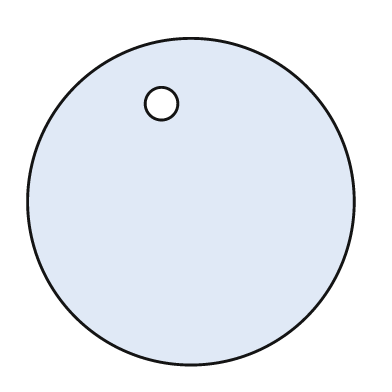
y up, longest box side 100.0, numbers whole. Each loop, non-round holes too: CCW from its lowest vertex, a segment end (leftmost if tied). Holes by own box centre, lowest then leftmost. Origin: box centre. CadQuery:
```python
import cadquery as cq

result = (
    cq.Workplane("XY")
    .moveTo(0.0, 0.0)
    .circle(50.0)
    .moveTo(-9.0, 30.0)
    .circle(5.0)
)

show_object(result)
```